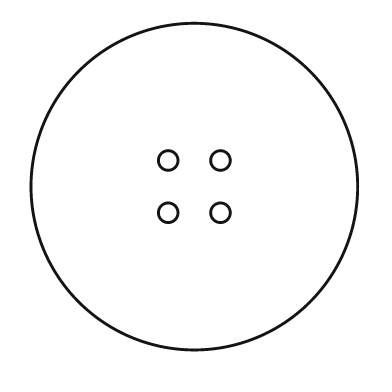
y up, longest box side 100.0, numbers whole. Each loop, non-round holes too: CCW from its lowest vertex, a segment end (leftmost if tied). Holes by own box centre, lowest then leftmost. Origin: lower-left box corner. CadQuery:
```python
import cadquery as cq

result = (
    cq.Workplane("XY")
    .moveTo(50.0, 50.0)
    .circle(50.0)
    .moveTo(42.0, 42.0)
    .circle(3.0)
    .moveTo(58.0, 42.0)
    .circle(3.0)
    .moveTo(42.0, 58.0)
    .circle(3.0)
    .moveTo(58.0, 58.0)
    .circle(3.0)
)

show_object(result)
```